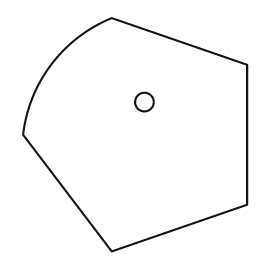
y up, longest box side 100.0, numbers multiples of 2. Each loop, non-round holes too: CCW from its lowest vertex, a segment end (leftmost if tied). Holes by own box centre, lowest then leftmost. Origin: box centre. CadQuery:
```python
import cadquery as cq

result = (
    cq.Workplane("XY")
    .moveTo(-10.0, -50.0)
    .lineTo(48.0, -30.0)
    .lineTo(48.0, 30.0)
    .lineTo(-10.0, 50.0)
    .threePointArc((-36.0, 30.0), (-48.0, 0.0))
    .close()
    .moveTo(4.0, 14.0)
    .circle(4.0)
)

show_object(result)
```